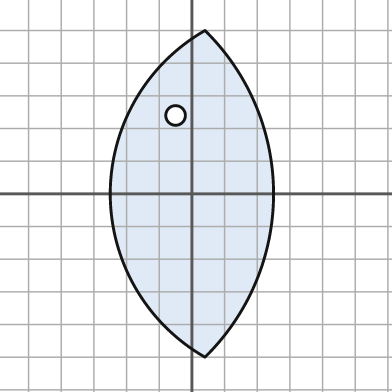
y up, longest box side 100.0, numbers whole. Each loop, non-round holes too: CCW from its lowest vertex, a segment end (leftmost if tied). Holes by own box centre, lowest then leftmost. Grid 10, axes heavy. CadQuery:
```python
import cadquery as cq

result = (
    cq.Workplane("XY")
    .moveTo(4.0, -50.0)
    .threePointArc((25.0, 0.0), (4.0, 50.0))
    .threePointArc((-25.0, 0.0), (4.0, -50.0))
    .close()
    .moveTo(-5.0, 24.0)
    .circle(3.0)
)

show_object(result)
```